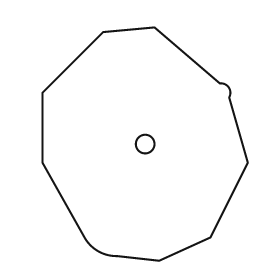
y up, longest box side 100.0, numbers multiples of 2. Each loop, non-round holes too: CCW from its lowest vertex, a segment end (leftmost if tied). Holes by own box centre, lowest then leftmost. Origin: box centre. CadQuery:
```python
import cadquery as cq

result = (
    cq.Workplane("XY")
    .moveTo(6.0, -50.0)
    .lineTo(28.0, -40.0)
    .lineTo(44.0, -8.0)
    .lineTo(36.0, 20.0)
    .threePointArc((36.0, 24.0), (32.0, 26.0))
    .lineTo(4.0, 50.0)
    .lineTo(-18.0, 48.0)
    .lineTo(-44.0, 22.0)
    .lineTo(-44.0, -8.0)
    .lineTo(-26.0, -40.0)
    .threePointArc((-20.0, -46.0), (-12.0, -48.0))
    .close()
    .moveTo(0.0, 0.0)
    .circle(4.0)
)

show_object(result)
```